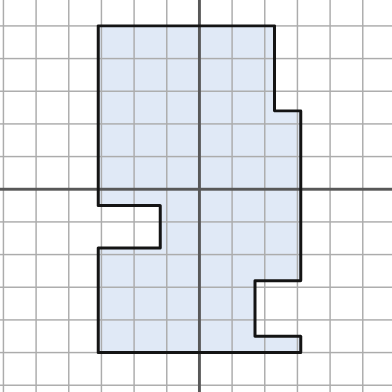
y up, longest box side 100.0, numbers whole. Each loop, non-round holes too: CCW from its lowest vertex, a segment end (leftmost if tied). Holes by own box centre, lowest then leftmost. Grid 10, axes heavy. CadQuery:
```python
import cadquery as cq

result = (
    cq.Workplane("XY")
    .moveTo(-31.0, -50.0)
    .lineTo(31.0, -50.0)
    .lineTo(31.0, -45.0)
    .lineTo(17.0, -45.0)
    .lineTo(17.0, -28.0)
    .lineTo(31.0, -28.0)
    .lineTo(31.0, 24.0)
    .lineTo(23.0, 24.0)
    .lineTo(23.0, 50.0)
    .lineTo(-31.0, 50.0)
    .lineTo(-31.0, -5.0)
    .lineTo(-12.0, -5.0)
    .lineTo(-12.0, -18.0)
    .lineTo(-31.0, -18.0)
    .close()
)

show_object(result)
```